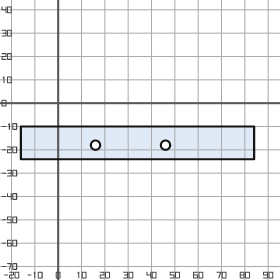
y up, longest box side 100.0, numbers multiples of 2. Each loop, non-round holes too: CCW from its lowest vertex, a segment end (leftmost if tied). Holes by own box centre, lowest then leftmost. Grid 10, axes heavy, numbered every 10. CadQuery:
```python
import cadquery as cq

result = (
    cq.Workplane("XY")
    .moveTo(-16.0, -24.0)
    .lineTo(84.0, -24.0)
    .lineTo(84.0, -10.0)
    .lineTo(-16.0, -10.0)
    .close()
    .moveTo(16.0, -18.0)
    .circle(2.0)
    .moveTo(46.0, -18.0)
    .circle(2.0)
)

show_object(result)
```